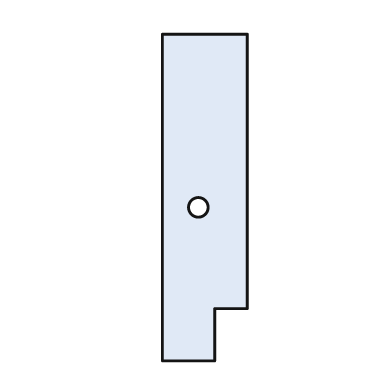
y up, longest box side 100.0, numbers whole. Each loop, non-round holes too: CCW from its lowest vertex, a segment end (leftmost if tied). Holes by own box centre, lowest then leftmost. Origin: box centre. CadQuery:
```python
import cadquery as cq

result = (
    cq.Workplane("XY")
    .moveTo(-13.0, -50.0)
    .lineTo(3.0, -50.0)
    .lineTo(3.0, -34.0)
    .lineTo(13.0, -34.0)
    .lineTo(13.0, 50.0)
    .lineTo(-13.0, 50.0)
    .close()
    .moveTo(-2.0, -3.0)
    .circle(3.0)
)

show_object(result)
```